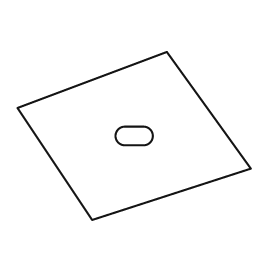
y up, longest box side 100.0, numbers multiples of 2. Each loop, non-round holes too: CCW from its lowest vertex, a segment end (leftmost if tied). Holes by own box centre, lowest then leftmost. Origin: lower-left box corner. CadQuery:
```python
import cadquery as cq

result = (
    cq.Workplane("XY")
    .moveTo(32.0, 0.0)
    .lineTo(100.0, 22.0)
    .lineTo(64.0, 72.0)
    .lineTo(0.0, 48.0)
    .close()
    .moveTo(46.0, 32.0)
    .lineTo(54.0, 32.0)
    .threePointArc((58.0, 36.0), (54.0, 40.0))
    .lineTo(46.0, 40.0)
    .threePointArc((42.0, 36.0), (46.0, 32.0))
    .close()
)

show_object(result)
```